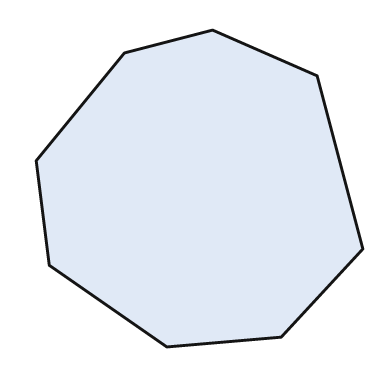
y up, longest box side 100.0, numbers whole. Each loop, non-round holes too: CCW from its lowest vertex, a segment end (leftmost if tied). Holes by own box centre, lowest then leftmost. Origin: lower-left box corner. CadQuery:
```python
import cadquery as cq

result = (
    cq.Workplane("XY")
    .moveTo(40.0, 0.0)
    .lineTo(75.0, 3.0)
    .lineTo(100.0, 30.0)
    .lineTo(86.0, 83.0)
    .lineTo(54.0, 97.0)
    .lineTo(27.0, 90.0)
    .lineTo(0.0, 57.0)
    .lineTo(4.0, 25.0)
    .close()
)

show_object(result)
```